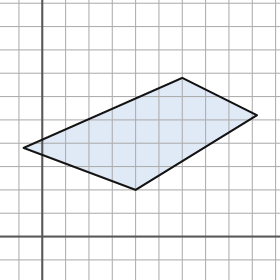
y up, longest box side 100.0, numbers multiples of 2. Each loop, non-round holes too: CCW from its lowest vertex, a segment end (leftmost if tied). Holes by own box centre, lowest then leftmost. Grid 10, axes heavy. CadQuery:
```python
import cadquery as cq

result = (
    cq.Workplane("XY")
    .moveTo(40.0, 20.0)
    .lineTo(92.0, 52.0)
    .lineTo(60.0, 68.0)
    .lineTo(-8.0, 38.0)
    .close()
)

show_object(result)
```